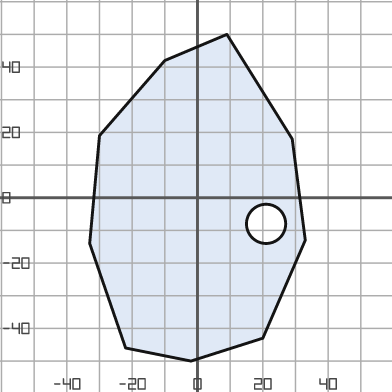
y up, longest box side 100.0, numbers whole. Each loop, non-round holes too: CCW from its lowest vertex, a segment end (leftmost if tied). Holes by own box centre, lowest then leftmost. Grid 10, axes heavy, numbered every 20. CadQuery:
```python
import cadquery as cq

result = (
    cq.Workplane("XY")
    .moveTo(-2.0, -50.0)
    .lineTo(20.0, -43.0)
    .lineTo(33.0, -13.0)
    .lineTo(29.0, 18.0)
    .lineTo(9.0, 50.0)
    .lineTo(-10.0, 42.0)
    .lineTo(-30.0, 19.0)
    .lineTo(-33.0, -14.0)
    .lineTo(-22.0, -46.0)
    .close()
    .moveTo(21.0, -8.0)
    .circle(6.0)
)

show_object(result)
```